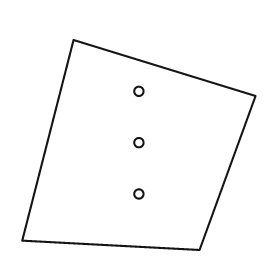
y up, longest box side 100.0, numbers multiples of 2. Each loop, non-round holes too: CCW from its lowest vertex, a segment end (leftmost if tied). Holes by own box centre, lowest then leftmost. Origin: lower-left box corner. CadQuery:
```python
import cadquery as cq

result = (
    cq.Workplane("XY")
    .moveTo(76.0, 0.0)
    .lineTo(100.0, 66.0)
    .lineTo(22.0, 90.0)
    .lineTo(0.0, 4.0)
    .close()
    .moveTo(50.0, 24.0)
    .circle(2.0)
    .moveTo(50.0, 46.0)
    .circle(2.0)
    .moveTo(50.0, 68.0)
    .circle(2.0)
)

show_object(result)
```